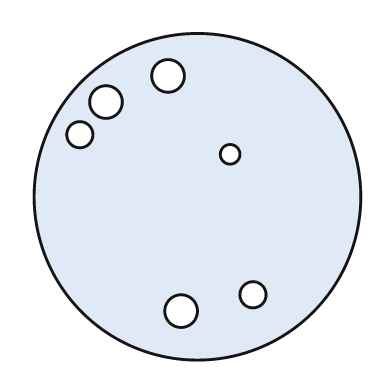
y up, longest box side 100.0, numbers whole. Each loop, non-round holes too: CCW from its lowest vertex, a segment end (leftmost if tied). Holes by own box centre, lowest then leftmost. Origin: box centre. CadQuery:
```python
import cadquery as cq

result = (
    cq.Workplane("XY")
    .moveTo(0.0, 0.0)
    .circle(50.0)
    .moveTo(-5.0, -35.0)
    .circle(5.0)
    .moveTo(17.0, -30.0)
    .circle(4.0)
    .moveTo(10.0, 13.0)
    .circle(3.0)
    .moveTo(-36.0, 19.0)
    .circle(4.0)
    .moveTo(-28.0, 29.0)
    .circle(5.0)
    .moveTo(-9.0, 37.0)
    .circle(5.0)
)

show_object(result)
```